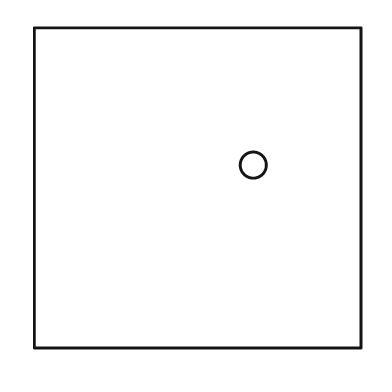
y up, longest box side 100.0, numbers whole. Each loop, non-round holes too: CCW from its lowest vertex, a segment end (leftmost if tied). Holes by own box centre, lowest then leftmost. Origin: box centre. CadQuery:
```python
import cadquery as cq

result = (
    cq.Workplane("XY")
    .moveTo(-50.0, -49.0)
    .lineTo(50.0, -49.0)
    .lineTo(50.0, 49.0)
    .lineTo(-50.0, 49.0)
    .close()
    .moveTo(17.0, 7.0)
    .circle(4.0)
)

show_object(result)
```